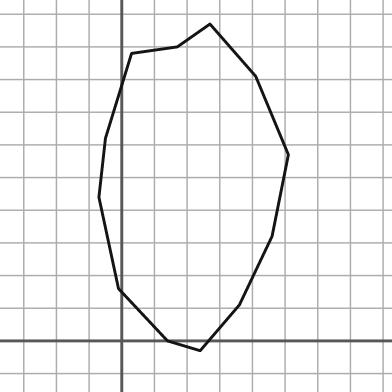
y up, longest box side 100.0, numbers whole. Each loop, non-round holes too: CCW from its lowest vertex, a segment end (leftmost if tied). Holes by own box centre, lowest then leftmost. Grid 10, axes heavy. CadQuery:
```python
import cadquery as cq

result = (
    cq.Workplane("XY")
    .moveTo(24.0, -3.0)
    .lineTo(36.0, 11.0)
    .lineTo(46.0, 32.0)
    .lineTo(51.0, 57.0)
    .lineTo(41.0, 81.0)
    .lineTo(27.0, 97.0)
    .lineTo(17.0, 90.0)
    .lineTo(3.0, 88.0)
    .lineTo(-5.0, 62.0)
    .lineTo(-7.0, 44.0)
    .lineTo(-1.0, 16.0)
    .lineTo(14.0, 0.0)
    .close()
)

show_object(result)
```